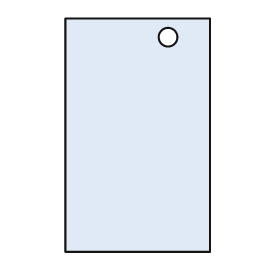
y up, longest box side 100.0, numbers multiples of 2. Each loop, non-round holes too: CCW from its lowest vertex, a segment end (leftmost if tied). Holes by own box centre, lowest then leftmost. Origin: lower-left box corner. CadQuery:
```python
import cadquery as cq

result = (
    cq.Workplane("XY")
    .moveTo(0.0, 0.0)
    .lineTo(62.0, 0.0)
    .lineTo(62.0, 100.0)
    .lineTo(0.0, 100.0)
    .close()
    .moveTo(44.0, 92.0)
    .circle(4.0)
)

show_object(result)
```